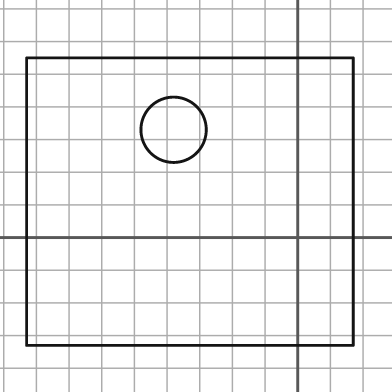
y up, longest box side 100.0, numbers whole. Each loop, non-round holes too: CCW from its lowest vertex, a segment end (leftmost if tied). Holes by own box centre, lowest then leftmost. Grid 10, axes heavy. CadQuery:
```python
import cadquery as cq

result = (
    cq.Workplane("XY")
    .moveTo(-83.0, -33.0)
    .lineTo(17.0, -33.0)
    .lineTo(17.0, 55.0)
    .lineTo(-83.0, 55.0)
    .close()
    .moveTo(-38.0, 33.0)
    .circle(10.0)
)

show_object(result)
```